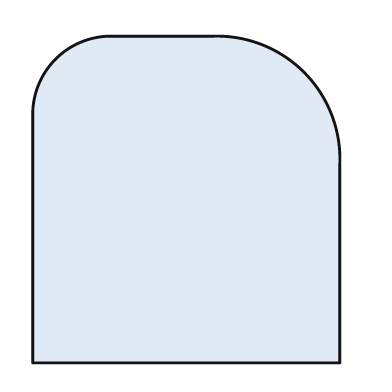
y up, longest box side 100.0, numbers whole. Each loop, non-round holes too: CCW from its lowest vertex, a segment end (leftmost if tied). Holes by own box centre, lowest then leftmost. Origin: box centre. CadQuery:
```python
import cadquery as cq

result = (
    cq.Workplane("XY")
    .moveTo(-47.0, -50.0)
    .lineTo(47.0, -50.0)
    .lineTo(47.0, 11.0)
    .threePointArc((36.0, 39.0), (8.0, 50.0))
    .lineTo(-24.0, 50.0)
    .threePointArc((-40.0, 43.0), (-47.0, 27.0))
    .close()
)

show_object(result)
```